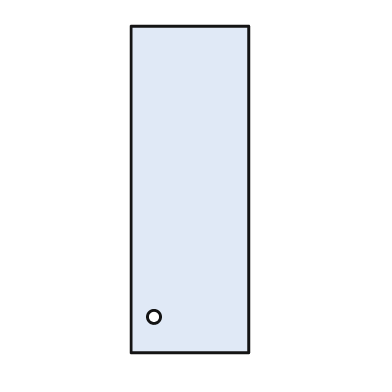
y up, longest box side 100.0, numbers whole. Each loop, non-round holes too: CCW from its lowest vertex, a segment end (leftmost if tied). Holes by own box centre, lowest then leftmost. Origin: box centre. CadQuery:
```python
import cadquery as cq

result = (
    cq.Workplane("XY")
    .moveTo(-18.0, -50.0)
    .lineTo(18.0, -50.0)
    .lineTo(18.0, 50.0)
    .lineTo(-18.0, 50.0)
    .close()
    .moveTo(-11.0, -39.0)
    .circle(2.0)
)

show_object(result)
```